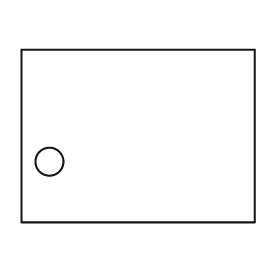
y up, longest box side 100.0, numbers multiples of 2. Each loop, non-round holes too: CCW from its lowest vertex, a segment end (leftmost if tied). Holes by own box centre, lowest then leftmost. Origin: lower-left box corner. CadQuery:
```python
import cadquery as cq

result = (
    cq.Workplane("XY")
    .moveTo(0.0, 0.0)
    .lineTo(100.0, 0.0)
    .lineTo(100.0, 74.0)
    .lineTo(0.0, 74.0)
    .close()
    .moveTo(12.0, 26.0)
    .circle(6.0)
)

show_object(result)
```